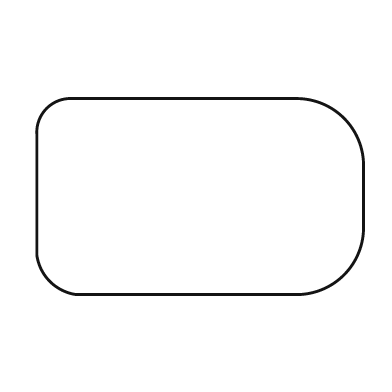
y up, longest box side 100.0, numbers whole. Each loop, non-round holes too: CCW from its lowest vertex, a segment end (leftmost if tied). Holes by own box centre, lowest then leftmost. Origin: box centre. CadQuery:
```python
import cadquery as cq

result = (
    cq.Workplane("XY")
    .moveTo(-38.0, -30.0)
    .lineTo(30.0, -30.0)
    .threePointArc((44.0, -24.0), (50.0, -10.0))
    .lineTo(50.0, 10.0)
    .threePointArc((44.0, 24.0), (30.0, 30.0))
    .lineTo(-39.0, 30.0)
    .threePointArc((-47.0, 27.0), (-50.0, 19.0))
    .lineTo(-50.0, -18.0)
    .threePointArc((-46.0, -26.0), (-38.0, -30.0))
    .close()
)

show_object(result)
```